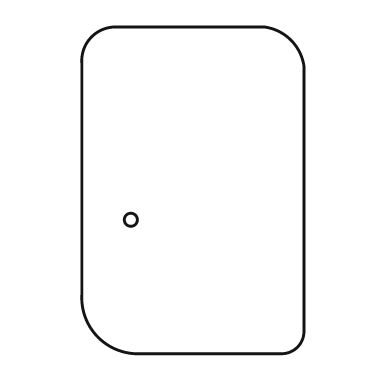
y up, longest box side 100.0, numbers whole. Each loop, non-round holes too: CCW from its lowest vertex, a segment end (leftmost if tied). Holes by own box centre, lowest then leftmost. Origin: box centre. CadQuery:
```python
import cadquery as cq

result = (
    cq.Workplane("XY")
    .moveTo(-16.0, -50.0)
    .lineTo(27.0, -50.0)
    .threePointArc((32.0, -48.0), (34.0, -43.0))
    .lineTo(34.0, 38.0)
    .threePointArc((30.0, 46.0), (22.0, 50.0))
    .lineTo(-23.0, 50.0)
    .threePointArc((-31.0, 47.0), (-34.0, 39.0))
    .lineTo(-34.0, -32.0)
    .threePointArc((-29.0, -45.0), (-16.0, -50.0))
    .close()
    .moveTo(-19.0, -9.0)
    .circle(2.0)
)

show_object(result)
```